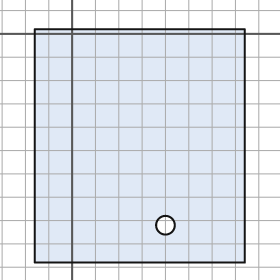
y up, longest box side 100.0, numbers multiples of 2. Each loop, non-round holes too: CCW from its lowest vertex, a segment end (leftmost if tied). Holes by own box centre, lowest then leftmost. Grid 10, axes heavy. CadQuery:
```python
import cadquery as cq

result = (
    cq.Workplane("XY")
    .moveTo(-16.0, -98.0)
    .lineTo(74.0, -98.0)
    .lineTo(74.0, 2.0)
    .lineTo(-16.0, 2.0)
    .close()
    .moveTo(40.0, -82.0)
    .circle(4.0)
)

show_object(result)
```